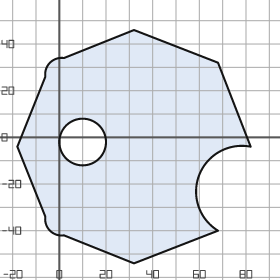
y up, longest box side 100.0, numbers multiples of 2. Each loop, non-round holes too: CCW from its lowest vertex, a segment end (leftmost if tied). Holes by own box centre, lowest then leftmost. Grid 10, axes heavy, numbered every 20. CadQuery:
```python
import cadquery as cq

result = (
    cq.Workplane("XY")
    .moveTo(32.0, -54.0)
    .lineTo(68.0, -40.0)
    .threePointArc((60.0, -16.0), (82.0, -4.0))
    .lineTo(68.0, 32.0)
    .lineTo(32.0, 46.0)
    .lineTo(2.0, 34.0)
    .threePointArc((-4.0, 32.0), (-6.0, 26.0))
    .lineTo(-18.0, -4.0)
    .lineTo(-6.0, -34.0)
    .threePointArc((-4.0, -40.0), (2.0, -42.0))
    .close()
    .moveTo(10.0, -2.0)
    .circle(10.0)
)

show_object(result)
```